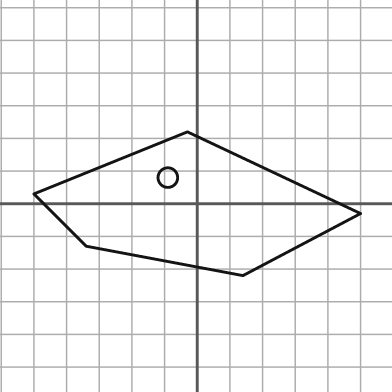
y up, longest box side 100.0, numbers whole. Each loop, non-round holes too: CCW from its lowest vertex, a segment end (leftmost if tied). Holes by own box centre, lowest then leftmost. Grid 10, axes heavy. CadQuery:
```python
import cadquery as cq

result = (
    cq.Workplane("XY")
    .moveTo(14.0, -22.0)
    .lineTo(50.0, -3.0)
    .lineTo(-3.0, 22.0)
    .lineTo(-50.0, 3.0)
    .lineTo(-34.0, -13.0)
    .close()
    .moveTo(-9.0, 8.0)
    .circle(3.0)
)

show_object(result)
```